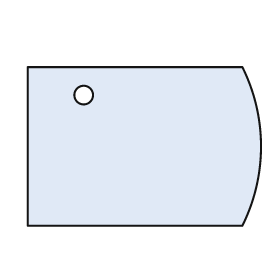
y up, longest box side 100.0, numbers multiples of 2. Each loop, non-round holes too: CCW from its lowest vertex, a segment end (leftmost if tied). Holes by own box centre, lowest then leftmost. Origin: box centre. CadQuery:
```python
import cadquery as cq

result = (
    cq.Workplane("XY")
    .moveTo(-50.0, -34.0)
    .lineTo(42.0, -34.0)
    .threePointArc((50.0, 0.0), (42.0, 34.0))
    .lineTo(-50.0, 34.0)
    .close()
    .moveTo(-26.0, 22.0)
    .circle(4.0)
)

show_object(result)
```